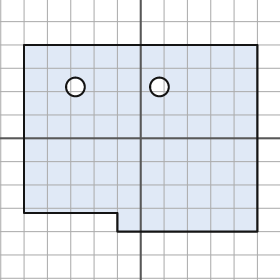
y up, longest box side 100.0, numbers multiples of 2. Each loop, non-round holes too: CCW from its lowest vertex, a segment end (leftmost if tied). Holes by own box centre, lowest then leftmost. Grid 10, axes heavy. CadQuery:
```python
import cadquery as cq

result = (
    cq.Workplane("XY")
    .moveTo(-10.0, -40.0)
    .lineTo(50.0, -40.0)
    .lineTo(50.0, 40.0)
    .lineTo(-50.0, 40.0)
    .lineTo(-50.0, -32.0)
    .lineTo(-10.0, -32.0)
    .close()
    .moveTo(-28.0, 22.0)
    .circle(4.0)
    .moveTo(8.0, 22.0)
    .circle(4.0)
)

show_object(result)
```